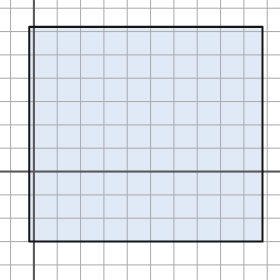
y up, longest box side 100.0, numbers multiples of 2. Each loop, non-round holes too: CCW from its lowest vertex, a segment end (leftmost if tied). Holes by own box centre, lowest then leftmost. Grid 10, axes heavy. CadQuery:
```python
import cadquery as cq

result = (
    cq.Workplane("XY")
    .moveTo(-2.0, -30.0)
    .lineTo(98.0, -30.0)
    .lineTo(98.0, 62.0)
    .lineTo(-2.0, 62.0)
    .close()
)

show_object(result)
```